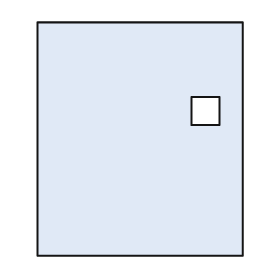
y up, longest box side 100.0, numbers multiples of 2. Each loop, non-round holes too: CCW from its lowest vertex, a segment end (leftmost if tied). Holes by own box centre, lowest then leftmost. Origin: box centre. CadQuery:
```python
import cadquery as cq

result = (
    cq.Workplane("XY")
    .moveTo(-44.0, -50.0)
    .lineTo(44.0, -50.0)
    .lineTo(44.0, 50.0)
    .lineTo(-44.0, 50.0)
    .close()
    .moveTo(22.0, 6.0)
    .lineTo(34.0, 6.0)
    .lineTo(34.0, 18.0)
    .lineTo(22.0, 18.0)
    .close()
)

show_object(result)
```